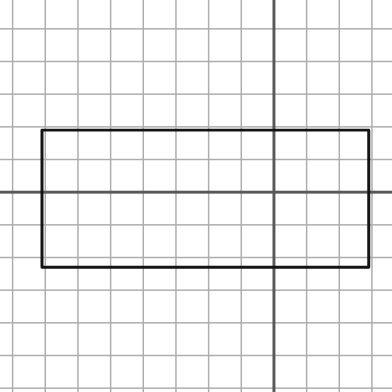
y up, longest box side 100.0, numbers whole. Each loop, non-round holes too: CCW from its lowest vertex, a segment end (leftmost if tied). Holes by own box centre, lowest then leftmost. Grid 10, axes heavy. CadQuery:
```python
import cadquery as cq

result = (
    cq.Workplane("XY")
    .moveTo(-71.0, -23.0)
    .lineTo(29.0, -23.0)
    .lineTo(29.0, 19.0)
    .lineTo(-71.0, 19.0)
    .close()
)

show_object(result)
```